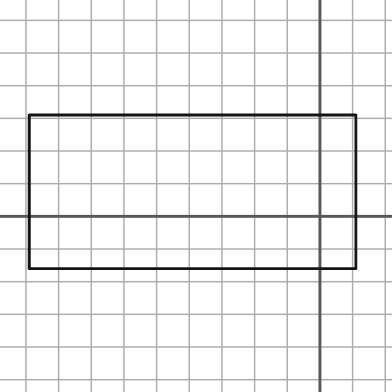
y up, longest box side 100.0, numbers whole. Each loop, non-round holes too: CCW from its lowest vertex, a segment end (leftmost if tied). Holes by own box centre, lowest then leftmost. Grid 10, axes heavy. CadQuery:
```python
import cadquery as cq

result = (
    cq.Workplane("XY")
    .moveTo(-89.0, -16.0)
    .lineTo(11.0, -16.0)
    .lineTo(11.0, 31.0)
    .lineTo(-89.0, 31.0)
    .close()
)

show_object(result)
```